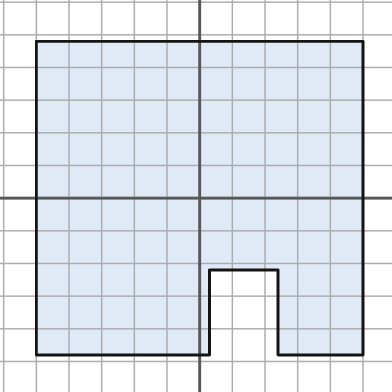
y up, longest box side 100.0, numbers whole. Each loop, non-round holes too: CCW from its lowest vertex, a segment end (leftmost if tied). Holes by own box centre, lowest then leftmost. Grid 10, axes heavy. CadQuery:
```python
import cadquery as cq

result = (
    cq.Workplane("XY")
    .moveTo(-50.0, -48.0)
    .lineTo(3.0, -48.0)
    .lineTo(3.0, -22.0)
    .lineTo(24.0, -22.0)
    .lineTo(24.0, -48.0)
    .lineTo(50.0, -48.0)
    .lineTo(50.0, 48.0)
    .lineTo(-50.0, 48.0)
    .close()
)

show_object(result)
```